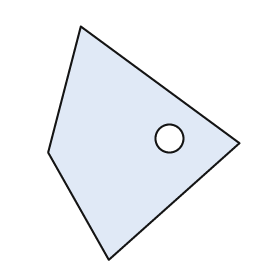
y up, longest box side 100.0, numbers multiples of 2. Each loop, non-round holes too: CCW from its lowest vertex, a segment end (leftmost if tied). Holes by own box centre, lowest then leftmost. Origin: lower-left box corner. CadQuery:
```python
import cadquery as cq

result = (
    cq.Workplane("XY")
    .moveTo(26.0, 0.0)
    .lineTo(82.0, 50.0)
    .lineTo(14.0, 100.0)
    .lineTo(0.0, 46.0)
    .close()
    .moveTo(52.0, 52.0)
    .circle(6.0)
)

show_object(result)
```